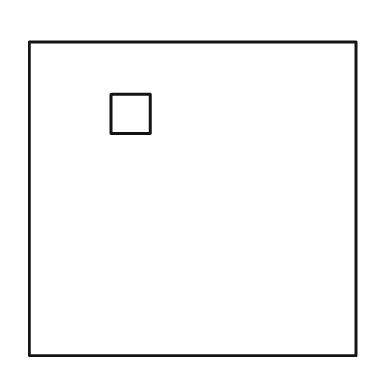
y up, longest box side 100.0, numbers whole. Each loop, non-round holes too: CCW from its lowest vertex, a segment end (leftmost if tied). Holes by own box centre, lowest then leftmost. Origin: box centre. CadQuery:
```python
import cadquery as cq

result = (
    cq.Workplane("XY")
    .moveTo(-50.0, -48.0)
    .lineTo(50.0, -48.0)
    .lineTo(50.0, 48.0)
    .lineTo(-50.0, 48.0)
    .close()
    .moveTo(-25.0, 20.0)
    .lineTo(-13.0, 20.0)
    .lineTo(-13.0, 32.0)
    .lineTo(-25.0, 32.0)
    .close()
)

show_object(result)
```